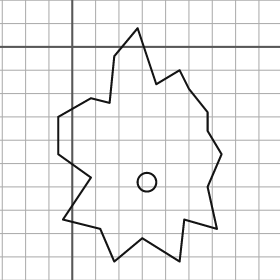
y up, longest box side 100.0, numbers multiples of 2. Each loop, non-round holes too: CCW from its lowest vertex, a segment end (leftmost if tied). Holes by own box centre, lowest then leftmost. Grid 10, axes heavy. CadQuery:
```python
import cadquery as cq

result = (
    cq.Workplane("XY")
    .moveTo(18.0, -92.0)
    .lineTo(30.0, -82.0)
    .lineTo(46.0, -92.0)
    .lineTo(48.0, -74.0)
    .lineTo(62.0, -78.0)
    .lineTo(58.0, -60.0)
    .lineTo(64.0, -46.0)
    .lineTo(58.0, -36.0)
    .lineTo(58.0, -28.0)
    .lineTo(50.0, -18.0)
    .lineTo(46.0, -10.0)
    .lineTo(36.0, -16.0)
    .lineTo(28.0, 8.0)
    .lineTo(18.0, -4.0)
    .lineTo(16.0, -24.0)
    .lineTo(8.0, -22.0)
    .lineTo(-6.0, -30.0)
    .lineTo(-6.0, -46.0)
    .lineTo(8.0, -56.0)
    .lineTo(-4.0, -74.0)
    .lineTo(12.0, -78.0)
    .close()
    .moveTo(32.0, -58.0)
    .circle(4.0)
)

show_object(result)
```